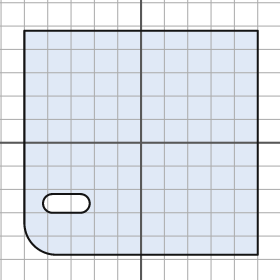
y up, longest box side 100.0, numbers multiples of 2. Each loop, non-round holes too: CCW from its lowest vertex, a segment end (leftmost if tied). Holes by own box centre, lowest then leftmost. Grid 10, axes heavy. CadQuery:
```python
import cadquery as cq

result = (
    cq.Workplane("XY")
    .moveTo(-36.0, -48.0)
    .lineTo(50.0, -48.0)
    .lineTo(50.0, 48.0)
    .lineTo(-50.0, 48.0)
    .lineTo(-50.0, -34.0)
    .threePointArc((-46.0, -44.0), (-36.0, -48.0))
    .close()
    .moveTo(-38.0, -30.0)
    .lineTo(-26.0, -30.0)
    .threePointArc((-22.0, -26.0), (-26.0, -22.0))
    .lineTo(-38.0, -22.0)
    .threePointArc((-42.0, -26.0), (-38.0, -30.0))
    .close()
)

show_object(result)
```